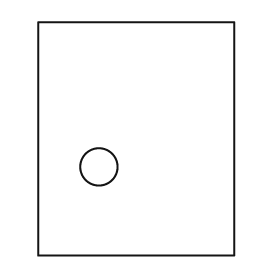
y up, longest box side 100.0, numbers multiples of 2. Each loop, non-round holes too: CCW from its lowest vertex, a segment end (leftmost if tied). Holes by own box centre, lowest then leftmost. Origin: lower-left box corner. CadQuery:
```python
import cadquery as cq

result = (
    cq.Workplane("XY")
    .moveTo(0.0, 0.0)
    .lineTo(84.0, 0.0)
    .lineTo(84.0, 100.0)
    .lineTo(0.0, 100.0)
    .close()
    .moveTo(26.0, 38.0)
    .circle(8.0)
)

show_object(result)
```